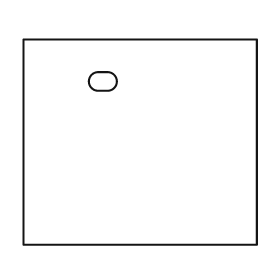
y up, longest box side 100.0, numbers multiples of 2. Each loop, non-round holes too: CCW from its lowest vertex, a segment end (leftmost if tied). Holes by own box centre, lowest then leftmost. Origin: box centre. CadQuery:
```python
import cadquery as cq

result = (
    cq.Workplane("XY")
    .moveTo(-50.0, -44.0)
    .lineTo(50.0, -44.0)
    .lineTo(50.0, 44.0)
    .lineTo(-50.0, 44.0)
    .close()
    .moveTo(-18.0, 22.0)
    .lineTo(-14.0, 22.0)
    .threePointArc((-10.0, 26.0), (-14.0, 30.0))
    .lineTo(-18.0, 30.0)
    .threePointArc((-22.0, 26.0), (-18.0, 22.0))
    .close()
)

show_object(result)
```